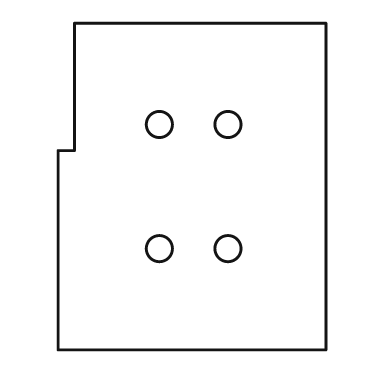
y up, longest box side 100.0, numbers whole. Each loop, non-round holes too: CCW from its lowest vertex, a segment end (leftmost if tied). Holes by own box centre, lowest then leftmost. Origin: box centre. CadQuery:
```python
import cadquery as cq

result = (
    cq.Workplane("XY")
    .moveTo(-41.0, -50.0)
    .lineTo(41.0, -50.0)
    .lineTo(41.0, 50.0)
    .lineTo(-36.0, 50.0)
    .lineTo(-36.0, 11.0)
    .lineTo(-41.0, 11.0)
    .close()
    .moveTo(-10.0, -19.0)
    .circle(4.0)
    .moveTo(11.0, -19.0)
    .circle(4.0)
    .moveTo(-10.0, 19.0)
    .circle(4.0)
    .moveTo(11.0, 19.0)
    .circle(4.0)
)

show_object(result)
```